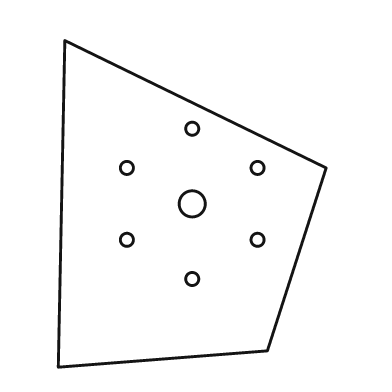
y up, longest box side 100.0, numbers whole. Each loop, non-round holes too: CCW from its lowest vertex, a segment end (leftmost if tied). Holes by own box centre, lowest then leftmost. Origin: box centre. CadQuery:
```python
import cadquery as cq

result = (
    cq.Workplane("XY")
    .moveTo(-41.0, -50.0)
    .lineTo(23.0, -45.0)
    .lineTo(41.0, 11.0)
    .lineTo(-39.0, 50.0)
    .close()
    .moveTo(0.0, -23.0)
    .circle(2.0)
    .moveTo(-20.0, -11.0)
    .circle(2.0)
    .moveTo(20.0, -11.0)
    .circle(2.0)
    .moveTo(0.0, 0.0)
    .circle(4.0)
    .moveTo(-20.0, 11.0)
    .circle(2.0)
    .moveTo(20.0, 11.0)
    .circle(2.0)
    .moveTo(0.0, 23.0)
    .circle(2.0)
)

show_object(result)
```